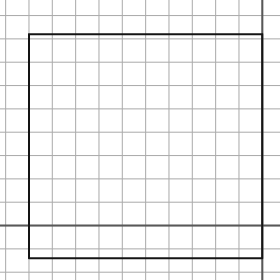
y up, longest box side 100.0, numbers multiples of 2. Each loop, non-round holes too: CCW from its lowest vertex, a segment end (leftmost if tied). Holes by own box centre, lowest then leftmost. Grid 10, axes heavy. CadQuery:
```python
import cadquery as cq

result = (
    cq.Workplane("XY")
    .moveTo(-100.0, -14.0)
    .lineTo(0.0, -14.0)
    .lineTo(0.0, 82.0)
    .lineTo(-100.0, 82.0)
    .close()
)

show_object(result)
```